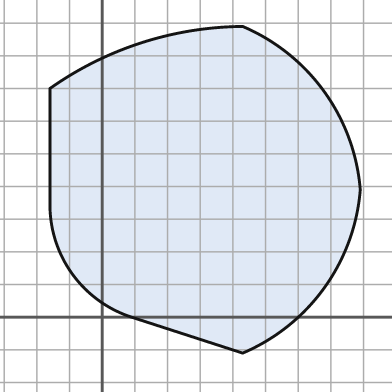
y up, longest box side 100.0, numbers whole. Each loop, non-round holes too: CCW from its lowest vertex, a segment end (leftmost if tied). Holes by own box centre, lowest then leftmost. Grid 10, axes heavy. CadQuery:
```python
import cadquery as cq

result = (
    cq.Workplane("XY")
    .moveTo(43.0, -11.0)
    .threePointArc((68.0, 9.0), (79.0, 39.0))
    .threePointArc((68.0, 69.0), (43.0, 89.0))
    .threePointArc((12.0, 84.0), (-16.0, 70.0))
    .lineTo(-16.0, 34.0)
    .threePointArc((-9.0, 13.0), (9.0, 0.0))
    .close()
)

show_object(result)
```